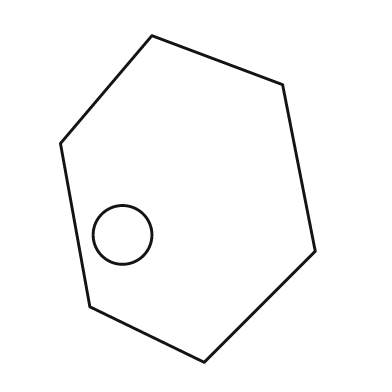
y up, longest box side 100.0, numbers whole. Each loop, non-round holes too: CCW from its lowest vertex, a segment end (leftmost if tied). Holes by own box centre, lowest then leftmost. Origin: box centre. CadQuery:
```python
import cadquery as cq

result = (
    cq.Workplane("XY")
    .moveTo(5.0, -50.0)
    .lineTo(39.0, -16.0)
    .lineTo(29.0, 35.0)
    .lineTo(-11.0, 50.0)
    .lineTo(-39.0, 17.0)
    .lineTo(-30.0, -33.0)
    .close()
    .moveTo(-20.0, -11.0)
    .circle(9.0)
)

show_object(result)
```